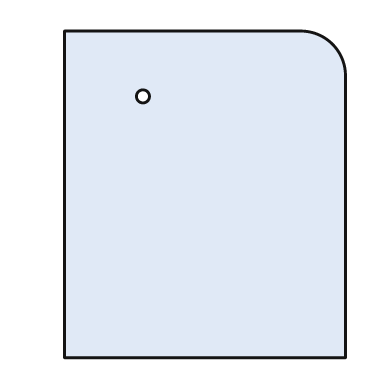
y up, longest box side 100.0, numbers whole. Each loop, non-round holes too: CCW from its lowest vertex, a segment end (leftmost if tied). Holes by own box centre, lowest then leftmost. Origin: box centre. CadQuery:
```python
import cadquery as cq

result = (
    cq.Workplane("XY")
    .moveTo(-43.0, -50.0)
    .lineTo(43.0, -50.0)
    .lineTo(43.0, 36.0)
    .threePointArc((39.0, 46.0), (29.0, 50.0))
    .lineTo(-43.0, 50.0)
    .close()
    .moveTo(-19.0, 30.0)
    .circle(2.0)
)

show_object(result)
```